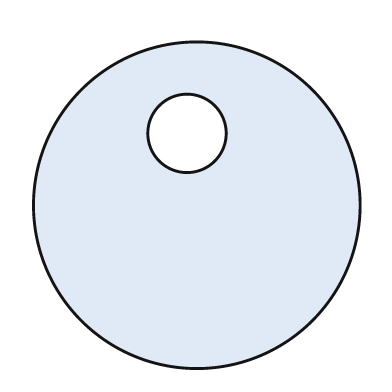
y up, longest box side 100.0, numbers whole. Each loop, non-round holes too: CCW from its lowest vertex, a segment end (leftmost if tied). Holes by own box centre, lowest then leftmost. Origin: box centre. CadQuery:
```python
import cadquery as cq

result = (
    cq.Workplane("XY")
    .moveTo(0.0, 0.0)
    .circle(50.0)
    .moveTo(-3.0, 22.0)
    .circle(12.0)
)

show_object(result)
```